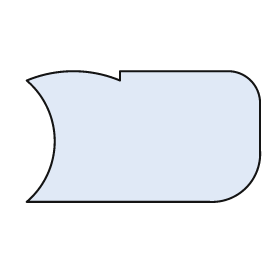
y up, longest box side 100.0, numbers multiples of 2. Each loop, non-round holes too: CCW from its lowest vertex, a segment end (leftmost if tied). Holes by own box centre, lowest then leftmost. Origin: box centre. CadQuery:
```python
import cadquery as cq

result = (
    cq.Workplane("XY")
    .moveTo(-50.0, -28.0)
    .lineTo(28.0, -28.0)
    .threePointArc((44.0, -22.0), (50.0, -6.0))
    .lineTo(50.0, 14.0)
    .threePointArc((46.0, 24.0), (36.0, 28.0))
    .lineTo(-10.0, 28.0)
    .lineTo(-10.0, 24.0)
    .threePointArc((-30.0, 28.0), (-50.0, 24.0))
    .threePointArc((-38.0, -2.0), (-50.0, -28.0))
    .close()
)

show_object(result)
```